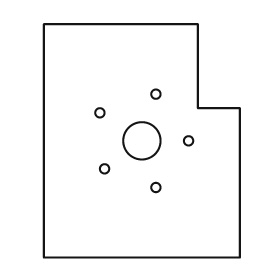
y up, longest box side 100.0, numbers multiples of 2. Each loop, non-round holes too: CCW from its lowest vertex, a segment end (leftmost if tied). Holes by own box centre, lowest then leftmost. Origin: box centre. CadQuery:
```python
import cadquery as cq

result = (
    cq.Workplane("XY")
    .moveTo(-42.0, -50.0)
    .lineTo(42.0, -50.0)
    .lineTo(42.0, 14.0)
    .lineTo(24.0, 14.0)
    .lineTo(24.0, 50.0)
    .lineTo(-42.0, 50.0)
    .close()
    .moveTo(6.0, -20.0)
    .circle(2.0)
    .moveTo(-16.0, -12.0)
    .circle(2.0)
    .moveTo(0.0, 0.0)
    .circle(8.0)
    .moveTo(20.0, 0.0)
    .circle(2.0)
    .moveTo(-18.0, 12.0)
    .circle(2.0)
    .moveTo(6.0, 20.0)
    .circle(2.0)
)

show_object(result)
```